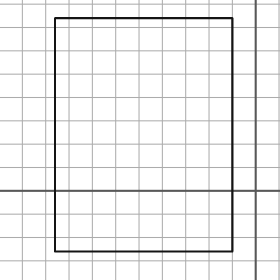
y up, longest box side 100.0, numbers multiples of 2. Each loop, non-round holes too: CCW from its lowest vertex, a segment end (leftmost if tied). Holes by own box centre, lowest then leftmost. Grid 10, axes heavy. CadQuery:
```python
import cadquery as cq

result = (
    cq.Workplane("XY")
    .moveTo(-86.0, -26.0)
    .lineTo(-10.0, -26.0)
    .lineTo(-10.0, 74.0)
    .lineTo(-86.0, 74.0)
    .close()
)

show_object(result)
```